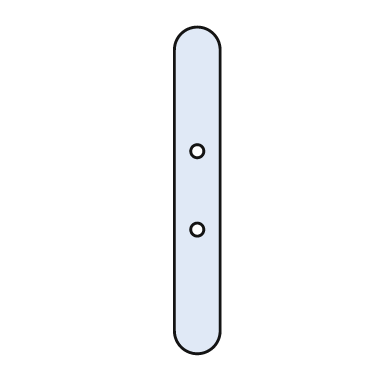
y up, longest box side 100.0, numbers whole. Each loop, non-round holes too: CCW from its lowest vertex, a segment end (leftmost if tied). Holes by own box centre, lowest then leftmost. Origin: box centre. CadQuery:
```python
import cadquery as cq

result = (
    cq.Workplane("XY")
    .moveTo(-7.0, -43.0)
    .threePointArc((0.0, -50.0), (7.0, -43.0))
    .lineTo(7.0, 43.0)
    .threePointArc((0.0, 50.0), (-7.0, 43.0))
    .close()
    .moveTo(0.0, -12.0)
    .circle(2.0)
    .moveTo(0.0, 12.0)
    .circle(2.0)
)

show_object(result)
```